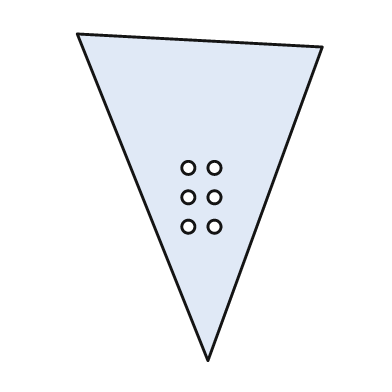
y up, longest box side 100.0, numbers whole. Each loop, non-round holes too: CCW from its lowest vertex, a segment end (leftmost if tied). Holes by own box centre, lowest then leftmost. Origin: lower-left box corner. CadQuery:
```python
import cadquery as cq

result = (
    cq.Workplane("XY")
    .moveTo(40.0, 0.0)
    .lineTo(75.0, 96.0)
    .lineTo(0.0, 100.0)
    .close()
    .moveTo(34.0, 41.0)
    .circle(2.0)
    .moveTo(42.0, 41.0)
    .circle(2.0)
    .moveTo(34.0, 50.0)
    .circle(2.0)
    .moveTo(42.0, 50.0)
    .circle(2.0)
    .moveTo(34.0, 59.0)
    .circle(2.0)
    .moveTo(42.0, 59.0)
    .circle(2.0)
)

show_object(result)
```